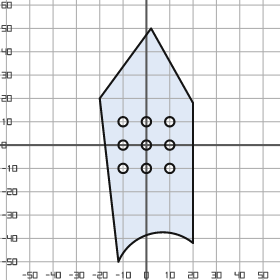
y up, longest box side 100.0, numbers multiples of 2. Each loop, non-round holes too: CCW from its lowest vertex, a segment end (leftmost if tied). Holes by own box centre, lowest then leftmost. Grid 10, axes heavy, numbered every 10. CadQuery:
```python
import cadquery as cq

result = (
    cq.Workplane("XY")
    .moveTo(-12.0, -50.0)
    .threePointArc((2.0, -38.0), (20.0, -42.0))
    .lineTo(20.0, 18.0)
    .lineTo(2.0, 50.0)
    .lineTo(-20.0, 20.0)
    .close()
    .moveTo(-10.0, -10.0)
    .circle(2.0)
    .moveTo(0.0, -10.0)
    .circle(2.0)
    .moveTo(10.0, -10.0)
    .circle(2.0)
    .moveTo(-10.0, 0.0)
    .circle(2.0)
    .moveTo(0.0, 0.0)
    .circle(2.0)
    .moveTo(10.0, 0.0)
    .circle(2.0)
    .moveTo(-10.0, 10.0)
    .circle(2.0)
    .moveTo(0.0, 10.0)
    .circle(2.0)
    .moveTo(10.0, 10.0)
    .circle(2.0)
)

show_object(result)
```